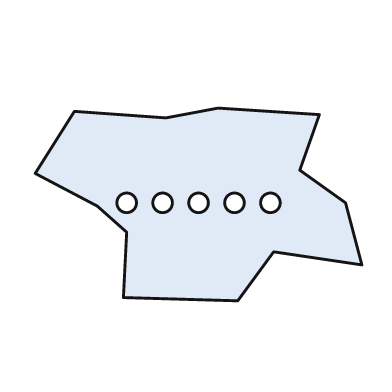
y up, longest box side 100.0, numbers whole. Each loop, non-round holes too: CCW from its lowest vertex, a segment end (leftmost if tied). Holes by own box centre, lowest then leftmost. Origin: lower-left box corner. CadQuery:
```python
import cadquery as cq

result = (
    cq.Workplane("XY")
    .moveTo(62.0, 0.0)
    .lineTo(73.0, 15.0)
    .lineTo(100.0, 11.0)
    .lineTo(95.0, 30.0)
    .lineTo(81.0, 40.0)
    .lineTo(87.0, 57.0)
    .lineTo(56.0, 59.0)
    .lineTo(40.0, 56.0)
    .lineTo(12.0, 58.0)
    .lineTo(0.0, 39.0)
    .lineTo(19.0, 29.0)
    .lineTo(28.0, 21.0)
    .lineTo(27.0, 1.0)
    .close()
    .moveTo(28.0, 30.0)
    .circle(3.0)
    .moveTo(39.0, 30.0)
    .circle(3.0)
    .moveTo(50.0, 30.0)
    .circle(3.0)
    .moveTo(61.0, 30.0)
    .circle(3.0)
    .moveTo(72.0, 30.0)
    .circle(3.0)
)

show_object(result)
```